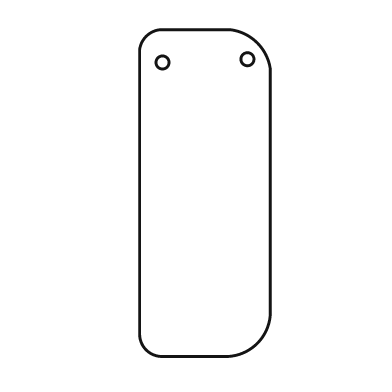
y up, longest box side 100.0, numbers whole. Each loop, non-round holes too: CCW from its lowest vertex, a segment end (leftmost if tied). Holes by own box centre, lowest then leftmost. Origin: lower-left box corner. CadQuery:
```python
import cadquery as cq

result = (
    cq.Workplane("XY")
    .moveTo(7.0, 0.0)
    .lineTo(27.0, 0.0)
    .threePointArc((36.0, 4.0), (40.0, 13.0))
    .lineTo(40.0, 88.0)
    .threePointArc((36.0, 96.0), (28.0, 100.0))
    .lineTo(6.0, 100.0)
    .threePointArc((2.0, 98.0), (0.0, 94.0))
    .lineTo(0.0, 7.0)
    .threePointArc((2.0, 2.0), (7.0, 0.0))
    .close()
    .moveTo(7.0, 90.0)
    .circle(2.0)
    .moveTo(33.0, 91.0)
    .circle(2.0)
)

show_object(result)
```